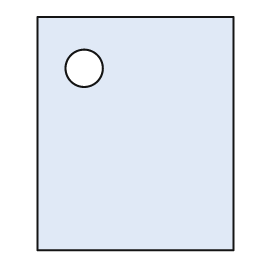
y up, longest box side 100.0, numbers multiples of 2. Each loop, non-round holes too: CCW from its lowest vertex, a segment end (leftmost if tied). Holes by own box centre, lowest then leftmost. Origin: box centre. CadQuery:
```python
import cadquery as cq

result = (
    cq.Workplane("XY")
    .moveTo(-42.0, -50.0)
    .lineTo(42.0, -50.0)
    .lineTo(42.0, 50.0)
    .lineTo(-42.0, 50.0)
    .close()
    .moveTo(-22.0, 28.0)
    .circle(8.0)
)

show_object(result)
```